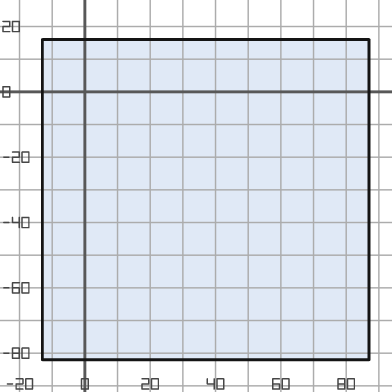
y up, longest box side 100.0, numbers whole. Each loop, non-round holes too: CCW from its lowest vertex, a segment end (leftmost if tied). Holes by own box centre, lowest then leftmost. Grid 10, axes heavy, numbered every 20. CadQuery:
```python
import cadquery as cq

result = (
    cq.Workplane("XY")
    .moveTo(-13.0, -82.0)
    .lineTo(87.0, -82.0)
    .lineTo(87.0, 16.0)
    .lineTo(-13.0, 16.0)
    .close()
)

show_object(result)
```